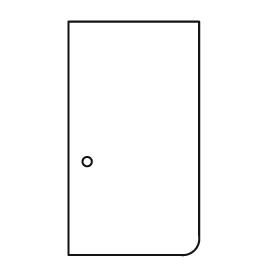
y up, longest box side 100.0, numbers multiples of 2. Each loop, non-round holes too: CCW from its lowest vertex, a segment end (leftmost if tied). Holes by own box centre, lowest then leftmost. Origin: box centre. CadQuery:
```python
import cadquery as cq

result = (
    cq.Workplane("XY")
    .moveTo(-28.0, -50.0)
    .lineTo(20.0, -50.0)
    .threePointArc((26.0, -48.0), (28.0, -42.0))
    .lineTo(28.0, 50.0)
    .lineTo(-28.0, 50.0)
    .close()
    .moveTo(-20.0, -10.0)
    .circle(2.0)
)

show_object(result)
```